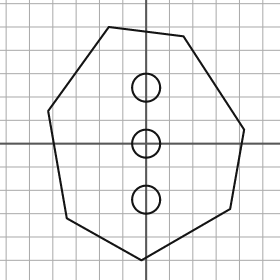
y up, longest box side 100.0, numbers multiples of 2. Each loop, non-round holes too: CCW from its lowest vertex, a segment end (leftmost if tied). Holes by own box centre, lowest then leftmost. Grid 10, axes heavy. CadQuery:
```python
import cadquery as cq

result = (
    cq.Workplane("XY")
    .moveTo(-2.0, -50.0)
    .lineTo(36.0, -28.0)
    .lineTo(42.0, 6.0)
    .lineTo(16.0, 46.0)
    .lineTo(-16.0, 50.0)
    .lineTo(-42.0, 14.0)
    .lineTo(-34.0, -32.0)
    .close()
    .moveTo(0.0, -24.0)
    .circle(6.0)
    .moveTo(0.0, 0.0)
    .circle(6.0)
    .moveTo(0.0, 24.0)
    .circle(6.0)
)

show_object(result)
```